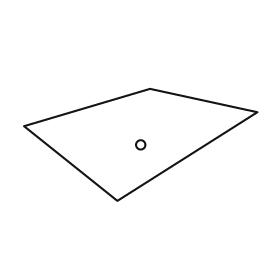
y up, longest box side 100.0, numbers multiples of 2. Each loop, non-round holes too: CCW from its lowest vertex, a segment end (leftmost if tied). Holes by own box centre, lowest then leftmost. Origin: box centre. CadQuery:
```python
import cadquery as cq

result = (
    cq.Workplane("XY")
    .moveTo(-10.0, -24.0)
    .lineTo(50.0, 14.0)
    .lineTo(4.0, 24.0)
    .lineTo(-50.0, 8.0)
    .close()
    .moveTo(0.0, 0.0)
    .circle(2.0)
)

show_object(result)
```